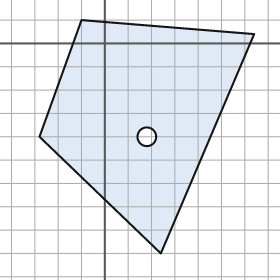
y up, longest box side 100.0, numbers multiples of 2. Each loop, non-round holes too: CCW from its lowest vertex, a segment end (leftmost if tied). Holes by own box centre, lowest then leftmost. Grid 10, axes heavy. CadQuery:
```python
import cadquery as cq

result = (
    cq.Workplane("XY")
    .moveTo(24.0, -90.0)
    .lineTo(64.0, 4.0)
    .lineTo(-10.0, 10.0)
    .lineTo(-28.0, -40.0)
    .close()
    .moveTo(18.0, -40.0)
    .circle(4.0)
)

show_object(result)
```